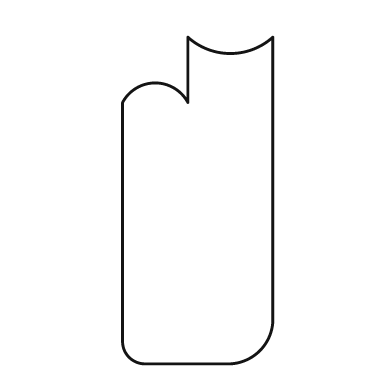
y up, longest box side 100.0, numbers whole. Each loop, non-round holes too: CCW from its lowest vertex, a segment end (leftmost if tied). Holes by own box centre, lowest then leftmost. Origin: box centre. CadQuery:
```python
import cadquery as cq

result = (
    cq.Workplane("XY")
    .moveTo(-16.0, -50.0)
    .lineTo(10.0, -50.0)
    .threePointArc((19.0, -46.0), (23.0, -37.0))
    .lineTo(23.0, 50.0)
    .threePointArc((10.0, 45.0), (-3.0, 50.0))
    .lineTo(-3.0, 30.0)
    .threePointArc((-13.0, 36.0), (-23.0, 30.0))
    .lineTo(-23.0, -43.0)
    .threePointArc((-21.0, -48.0), (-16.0, -50.0))
    .close()
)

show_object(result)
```